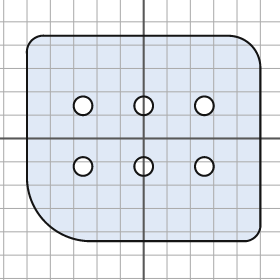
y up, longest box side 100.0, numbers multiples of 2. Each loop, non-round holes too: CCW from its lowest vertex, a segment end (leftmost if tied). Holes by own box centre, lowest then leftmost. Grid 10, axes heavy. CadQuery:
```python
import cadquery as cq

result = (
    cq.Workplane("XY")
    .moveTo(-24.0, -44.0)
    .lineTo(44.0, -44.0)
    .threePointArc((48.0, -42.0), (50.0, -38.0))
    .lineTo(50.0, 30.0)
    .threePointArc((46.0, 40.0), (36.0, 44.0))
    .lineTo(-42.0, 44.0)
    .threePointArc((-48.0, 42.0), (-50.0, 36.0))
    .lineTo(-50.0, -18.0)
    .threePointArc((-42.0, -36.0), (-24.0, -44.0))
    .close()
    .moveTo(-26.0, -12.0)
    .circle(4.0)
    .moveTo(0.0, -12.0)
    .circle(4.0)
    .moveTo(26.0, -12.0)
    .circle(4.0)
    .moveTo(-26.0, 14.0)
    .circle(4.0)
    .moveTo(0.0, 14.0)
    .circle(4.0)
    .moveTo(26.0, 14.0)
    .circle(4.0)
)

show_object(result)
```